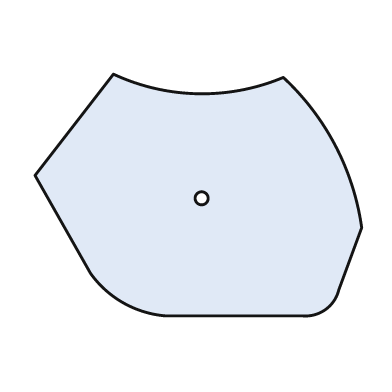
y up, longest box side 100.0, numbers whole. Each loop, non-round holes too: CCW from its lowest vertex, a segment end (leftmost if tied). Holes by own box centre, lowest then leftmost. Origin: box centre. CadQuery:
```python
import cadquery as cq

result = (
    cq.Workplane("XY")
    .moveTo(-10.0, -37.0)
    .lineTo(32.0, -37.0)
    .threePointArc((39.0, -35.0), (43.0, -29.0))
    .lineTo(50.0, -10.0)
    .threePointArc((42.0, 15.0), (26.0, 36.0))
    .threePointArc((0.0, 31.0), (-26.0, 37.0))
    .lineTo(-50.0, 6.0)
    .lineTo(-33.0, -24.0)
    .threePointArc((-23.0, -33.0), (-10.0, -37.0))
    .close()
    .moveTo(1.0, -1.0)
    .circle(2.0)
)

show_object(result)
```